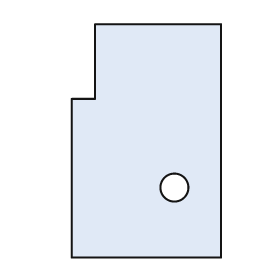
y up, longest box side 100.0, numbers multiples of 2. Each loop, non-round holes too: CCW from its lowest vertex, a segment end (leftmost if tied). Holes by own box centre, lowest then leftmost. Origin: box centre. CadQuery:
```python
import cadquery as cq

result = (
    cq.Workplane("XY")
    .moveTo(-32.0, -50.0)
    .lineTo(32.0, -50.0)
    .lineTo(32.0, 50.0)
    .lineTo(-22.0, 50.0)
    .lineTo(-22.0, 18.0)
    .lineTo(-32.0, 18.0)
    .close()
    .moveTo(12.0, -20.0)
    .circle(6.0)
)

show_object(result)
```